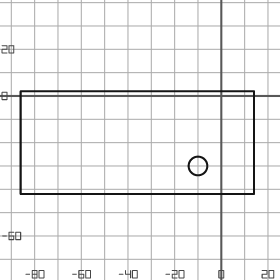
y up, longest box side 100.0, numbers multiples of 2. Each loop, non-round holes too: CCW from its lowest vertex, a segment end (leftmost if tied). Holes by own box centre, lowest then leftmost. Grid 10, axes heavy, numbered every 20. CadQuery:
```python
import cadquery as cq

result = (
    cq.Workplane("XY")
    .moveTo(-86.0, -42.0)
    .lineTo(14.0, -42.0)
    .lineTo(14.0, 2.0)
    .lineTo(-86.0, 2.0)
    .close()
    .moveTo(-10.0, -30.0)
    .circle(4.0)
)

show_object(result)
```